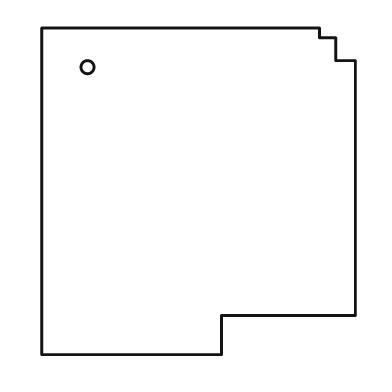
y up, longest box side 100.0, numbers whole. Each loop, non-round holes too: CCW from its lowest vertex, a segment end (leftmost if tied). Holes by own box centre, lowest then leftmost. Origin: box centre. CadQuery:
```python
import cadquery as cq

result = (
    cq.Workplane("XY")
    .moveTo(-48.0, -50.0)
    .lineTo(7.0, -50.0)
    .lineTo(7.0, -38.0)
    .lineTo(48.0, -38.0)
    .lineTo(48.0, 40.0)
    .lineTo(42.0, 40.0)
    .lineTo(42.0, 47.0)
    .lineTo(37.0, 47.0)
    .lineTo(37.0, 50.0)
    .lineTo(-48.0, 50.0)
    .close()
    .moveTo(-34.0, 38.0)
    .circle(2.0)
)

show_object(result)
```